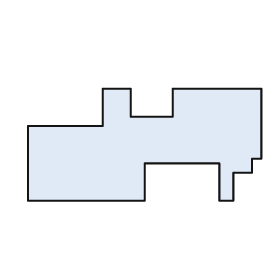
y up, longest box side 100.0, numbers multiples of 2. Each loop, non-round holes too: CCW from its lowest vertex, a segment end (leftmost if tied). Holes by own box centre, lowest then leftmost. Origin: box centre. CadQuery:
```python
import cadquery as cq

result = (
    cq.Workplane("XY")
    .moveTo(-50.0, -24.0)
    .lineTo(0.0, -24.0)
    .lineTo(0.0, -8.0)
    .lineTo(32.0, -8.0)
    .lineTo(32.0, -24.0)
    .lineTo(38.0, -24.0)
    .lineTo(38.0, -12.0)
    .lineTo(46.0, -12.0)
    .lineTo(46.0, -6.0)
    .lineTo(50.0, -6.0)
    .lineTo(50.0, 24.0)
    .lineTo(12.0, 24.0)
    .lineTo(12.0, 12.0)
    .lineTo(-6.0, 12.0)
    .lineTo(-6.0, 24.0)
    .lineTo(-18.0, 24.0)
    .lineTo(-18.0, 8.0)
    .lineTo(-50.0, 8.0)
    .close()
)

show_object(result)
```